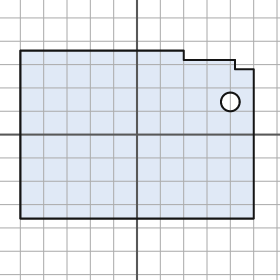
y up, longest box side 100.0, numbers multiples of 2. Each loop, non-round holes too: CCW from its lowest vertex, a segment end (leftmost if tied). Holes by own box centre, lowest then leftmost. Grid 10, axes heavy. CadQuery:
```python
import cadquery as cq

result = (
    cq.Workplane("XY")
    .moveTo(-50.0, -36.0)
    .lineTo(50.0, -36.0)
    .lineTo(50.0, 28.0)
    .lineTo(42.0, 28.0)
    .lineTo(42.0, 32.0)
    .lineTo(20.0, 32.0)
    .lineTo(20.0, 36.0)
    .lineTo(-50.0, 36.0)
    .close()
    .moveTo(40.0, 14.0)
    .circle(4.0)
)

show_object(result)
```